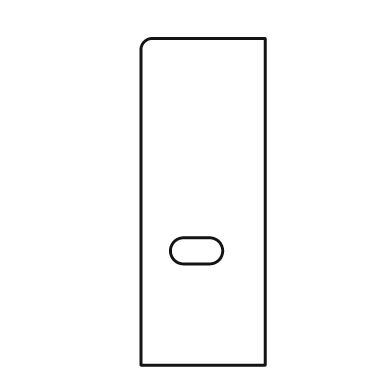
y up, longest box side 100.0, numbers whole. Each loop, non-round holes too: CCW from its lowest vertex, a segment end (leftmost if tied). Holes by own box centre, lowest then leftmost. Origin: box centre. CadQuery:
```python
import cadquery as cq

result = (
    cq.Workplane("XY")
    .moveTo(-19.0, -50.0)
    .lineTo(19.0, -50.0)
    .lineTo(19.0, 50.0)
    .lineTo(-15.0, 50.0)
    .threePointArc((-18.0, 49.0), (-19.0, 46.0))
    .close()
    .moveTo(-6.0, -19.0)
    .lineTo(2.0, -19.0)
    .threePointArc((6.0, -15.0), (2.0, -11.0))
    .lineTo(-6.0, -11.0)
    .threePointArc((-10.0, -15.0), (-6.0, -19.0))
    .close()
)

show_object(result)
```